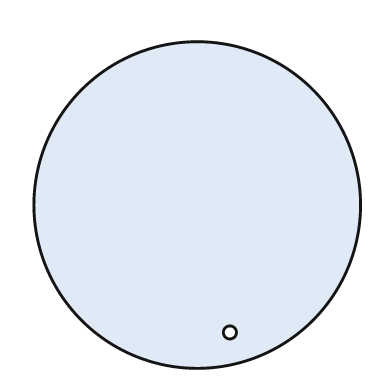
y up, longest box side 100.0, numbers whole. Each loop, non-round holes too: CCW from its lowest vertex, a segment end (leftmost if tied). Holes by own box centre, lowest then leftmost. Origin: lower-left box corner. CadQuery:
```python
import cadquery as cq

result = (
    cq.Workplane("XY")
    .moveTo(50.0, 50.0)
    .circle(50.0)
    .moveTo(60.0, 11.0)
    .circle(2.0)
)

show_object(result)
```